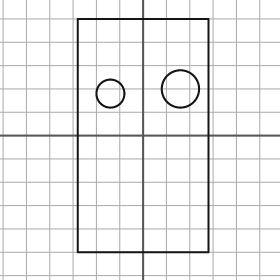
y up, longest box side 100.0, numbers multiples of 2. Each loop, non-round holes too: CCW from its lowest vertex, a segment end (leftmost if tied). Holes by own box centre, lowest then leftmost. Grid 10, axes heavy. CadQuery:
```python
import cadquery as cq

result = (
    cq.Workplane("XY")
    .moveTo(-28.0, -50.0)
    .lineTo(28.0, -50.0)
    .lineTo(28.0, 50.0)
    .lineTo(-28.0, 50.0)
    .close()
    .moveTo(-14.0, 18.0)
    .circle(6.0)
    .moveTo(16.0, 20.0)
    .circle(8.0)
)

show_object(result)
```